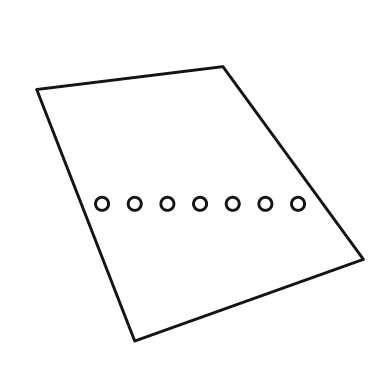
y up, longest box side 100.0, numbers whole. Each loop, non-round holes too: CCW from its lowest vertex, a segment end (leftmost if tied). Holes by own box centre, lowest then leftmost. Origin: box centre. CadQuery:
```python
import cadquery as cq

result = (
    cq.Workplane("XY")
    .moveTo(-20.0, -42.0)
    .lineTo(50.0, -17.0)
    .lineTo(7.0, 42.0)
    .lineTo(-50.0, 35.0)
    .close()
    .moveTo(-30.0, 0.0)
    .circle(2.0)
    .moveTo(-20.0, 0.0)
    .circle(2.0)
    .moveTo(-10.0, 0.0)
    .circle(2.0)
    .moveTo(0.0, 0.0)
    .circle(2.0)
    .moveTo(10.0, 0.0)
    .circle(2.0)
    .moveTo(20.0, 0.0)
    .circle(2.0)
    .moveTo(30.0, 0.0)
    .circle(2.0)
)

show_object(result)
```